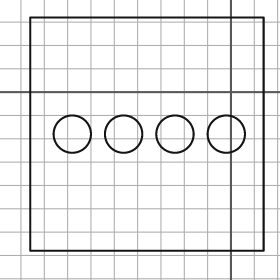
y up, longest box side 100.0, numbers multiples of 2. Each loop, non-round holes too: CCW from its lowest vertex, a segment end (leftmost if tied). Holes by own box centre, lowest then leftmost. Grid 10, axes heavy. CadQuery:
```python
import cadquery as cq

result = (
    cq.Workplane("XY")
    .moveTo(-86.0, -68.0)
    .lineTo(14.0, -68.0)
    .lineTo(14.0, 32.0)
    .lineTo(-86.0, 32.0)
    .close()
    .moveTo(-68.0, -18.0)
    .circle(8.0)
    .moveTo(-46.0, -18.0)
    .circle(8.0)
    .moveTo(-24.0, -18.0)
    .circle(8.0)
    .moveTo(-2.0, -18.0)
    .circle(8.0)
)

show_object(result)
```